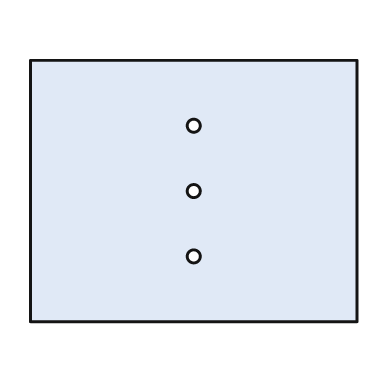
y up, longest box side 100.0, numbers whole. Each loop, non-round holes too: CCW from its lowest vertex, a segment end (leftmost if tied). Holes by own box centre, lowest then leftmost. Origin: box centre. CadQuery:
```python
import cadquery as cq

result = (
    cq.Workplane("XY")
    .moveTo(-50.0, -40.0)
    .lineTo(50.0, -40.0)
    .lineTo(50.0, 40.0)
    .lineTo(-50.0, 40.0)
    .close()
    .moveTo(0.0, -20.0)
    .circle(2.0)
    .moveTo(0.0, 0.0)
    .circle(2.0)
    .moveTo(0.0, 20.0)
    .circle(2.0)
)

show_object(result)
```